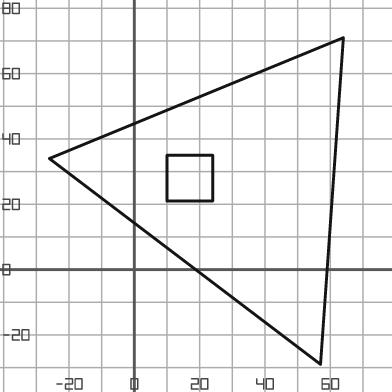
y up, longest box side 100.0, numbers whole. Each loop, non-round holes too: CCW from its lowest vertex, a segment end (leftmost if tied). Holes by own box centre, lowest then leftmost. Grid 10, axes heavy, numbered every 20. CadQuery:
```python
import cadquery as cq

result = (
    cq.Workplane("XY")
    .moveTo(57.0, -29.0)
    .lineTo(64.0, 71.0)
    .lineTo(-26.0, 34.0)
    .close()
    .moveTo(10.0, 21.0)
    .lineTo(24.0, 21.0)
    .lineTo(24.0, 35.0)
    .lineTo(10.0, 35.0)
    .close()
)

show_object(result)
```